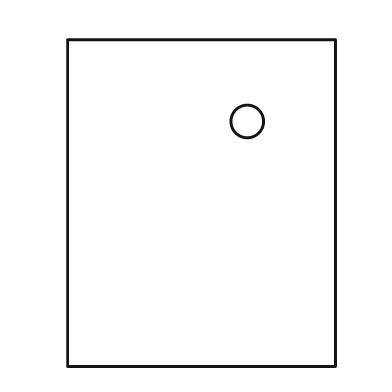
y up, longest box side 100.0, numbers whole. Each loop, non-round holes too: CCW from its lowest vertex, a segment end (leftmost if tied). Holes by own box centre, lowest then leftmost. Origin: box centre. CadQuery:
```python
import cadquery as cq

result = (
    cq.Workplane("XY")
    .moveTo(-41.0, -50.0)
    .lineTo(41.0, -50.0)
    .lineTo(41.0, 50.0)
    .lineTo(-41.0, 50.0)
    .close()
    .moveTo(14.0, 25.0)
    .circle(5.0)
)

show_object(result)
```